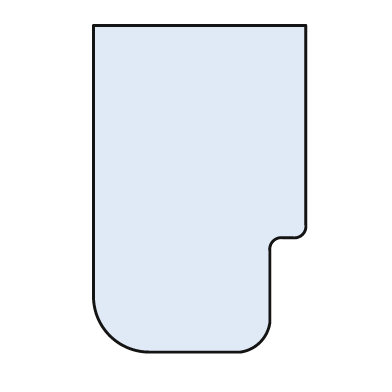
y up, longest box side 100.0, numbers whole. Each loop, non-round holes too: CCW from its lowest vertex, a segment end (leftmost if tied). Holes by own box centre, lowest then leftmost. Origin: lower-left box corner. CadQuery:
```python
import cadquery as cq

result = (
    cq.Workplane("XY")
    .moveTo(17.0, 0.0)
    .lineTo(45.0, 0.0)
    .threePointArc((51.0, 3.0), (54.0, 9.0))
    .lineTo(54.0, 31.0)
    .threePointArc((55.0, 34.0), (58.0, 35.0))
    .lineTo(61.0, 35.0)
    .threePointArc((64.0, 36.0), (65.0, 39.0))
    .lineTo(65.0, 100.0)
    .lineTo(0.0, 100.0)
    .lineTo(0.0, 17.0)
    .threePointArc((5.0, 5.0), (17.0, 0.0))
    .close()
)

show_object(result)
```